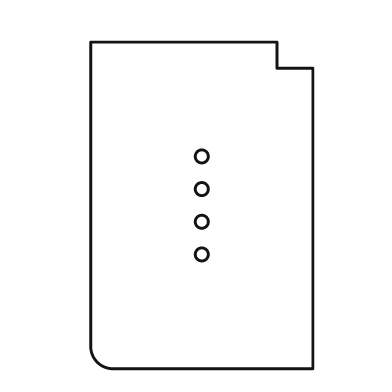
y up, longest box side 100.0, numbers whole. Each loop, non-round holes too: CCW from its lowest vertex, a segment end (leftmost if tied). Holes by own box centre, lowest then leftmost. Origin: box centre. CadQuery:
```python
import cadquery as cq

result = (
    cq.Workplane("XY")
    .moveTo(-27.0, -50.0)
    .lineTo(34.0, -50.0)
    .lineTo(34.0, 42.0)
    .lineTo(23.0, 42.0)
    .lineTo(23.0, 50.0)
    .lineTo(-34.0, 50.0)
    .lineTo(-34.0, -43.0)
    .threePointArc((-32.0, -48.0), (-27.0, -50.0))
    .close()
    .moveTo(0.0, -15.0)
    .circle(2.0)
    .moveTo(0.0, -5.0)
    .circle(2.0)
    .moveTo(0.0, 5.0)
    .circle(2.0)
    .moveTo(0.0, 15.0)
    .circle(2.0)
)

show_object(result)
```